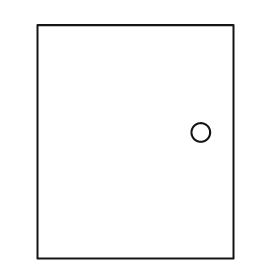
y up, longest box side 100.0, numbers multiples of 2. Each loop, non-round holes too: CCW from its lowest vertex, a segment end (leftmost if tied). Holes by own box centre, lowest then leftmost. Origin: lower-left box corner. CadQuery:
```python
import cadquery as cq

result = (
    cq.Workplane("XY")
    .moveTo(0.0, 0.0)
    .lineTo(84.0, 0.0)
    .lineTo(84.0, 100.0)
    .lineTo(0.0, 100.0)
    .close()
    .moveTo(70.0, 54.0)
    .circle(4.0)
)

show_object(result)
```